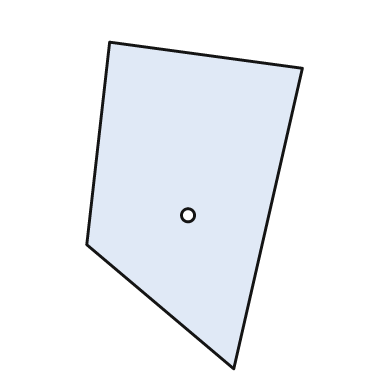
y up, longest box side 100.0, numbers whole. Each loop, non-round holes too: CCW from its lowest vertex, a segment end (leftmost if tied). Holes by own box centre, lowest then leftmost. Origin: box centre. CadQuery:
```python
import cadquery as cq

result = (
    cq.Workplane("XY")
    .moveTo(12.0, -50.0)
    .lineTo(33.0, 42.0)
    .lineTo(-26.0, 50.0)
    .lineTo(-33.0, -12.0)
    .close()
    .moveTo(-2.0, -3.0)
    .circle(2.0)
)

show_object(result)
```